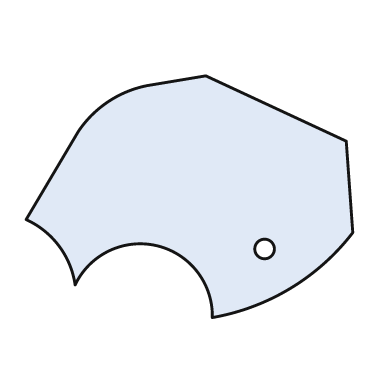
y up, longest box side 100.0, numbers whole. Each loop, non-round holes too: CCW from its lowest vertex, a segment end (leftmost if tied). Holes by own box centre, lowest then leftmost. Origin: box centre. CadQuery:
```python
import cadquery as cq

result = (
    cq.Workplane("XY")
    .moveTo(7.0, -37.0)
    .threePointArc((31.0, -28.0), (50.0, -11.0))
    .lineTo(48.0, 17.0)
    .lineTo(5.0, 37.0)
    .lineTo(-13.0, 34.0)
    .threePointArc((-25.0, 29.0), (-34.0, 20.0))
    .lineTo(-50.0, -7.0)
    .threePointArc((-40.0, -15.0), (-35.0, -27.0))
    .threePointArc((-10.0, -15.0), (7.0, -37.0))
    .close()
    .moveTo(23.0, -16.0)
    .circle(3.0)
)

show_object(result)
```